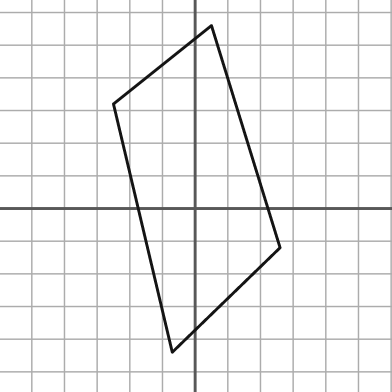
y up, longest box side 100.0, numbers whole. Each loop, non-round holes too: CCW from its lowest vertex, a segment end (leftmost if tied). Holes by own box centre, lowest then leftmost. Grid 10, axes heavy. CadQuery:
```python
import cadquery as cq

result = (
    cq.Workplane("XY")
    .moveTo(-7.0, -44.0)
    .lineTo(26.0, -12.0)
    .lineTo(5.0, 56.0)
    .lineTo(-25.0, 32.0)
    .close()
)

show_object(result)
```